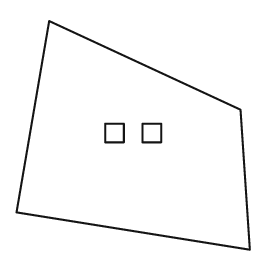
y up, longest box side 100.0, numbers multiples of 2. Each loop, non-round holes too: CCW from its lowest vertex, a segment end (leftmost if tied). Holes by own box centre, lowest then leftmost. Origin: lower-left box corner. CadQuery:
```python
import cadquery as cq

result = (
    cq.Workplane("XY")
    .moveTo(100.0, 0.0)
    .lineTo(96.0, 60.0)
    .lineTo(14.0, 98.0)
    .lineTo(0.0, 16.0)
    .close()
    .moveTo(38.0, 46.0)
    .lineTo(46.0, 46.0)
    .lineTo(46.0, 54.0)
    .lineTo(38.0, 54.0)
    .close()
    .moveTo(54.0, 46.0)
    .lineTo(62.0, 46.0)
    .lineTo(62.0, 54.0)
    .lineTo(54.0, 54.0)
    .close()
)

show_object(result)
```